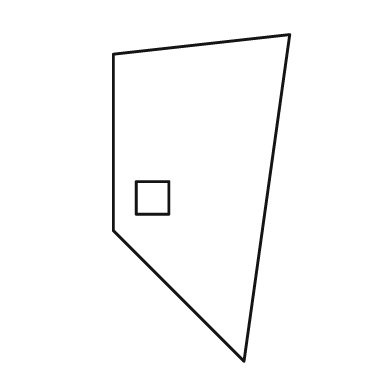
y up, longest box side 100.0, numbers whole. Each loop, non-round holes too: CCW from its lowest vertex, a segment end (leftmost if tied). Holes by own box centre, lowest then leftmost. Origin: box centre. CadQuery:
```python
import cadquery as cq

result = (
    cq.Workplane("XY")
    .moveTo(13.0, -50.0)
    .lineTo(27.0, 50.0)
    .lineTo(-27.0, 44.0)
    .lineTo(-27.0, -10.0)
    .close()
    .moveTo(-20.0, -5.0)
    .lineTo(-10.0, -5.0)
    .lineTo(-10.0, 5.0)
    .lineTo(-20.0, 5.0)
    .close()
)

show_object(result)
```